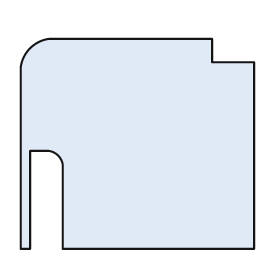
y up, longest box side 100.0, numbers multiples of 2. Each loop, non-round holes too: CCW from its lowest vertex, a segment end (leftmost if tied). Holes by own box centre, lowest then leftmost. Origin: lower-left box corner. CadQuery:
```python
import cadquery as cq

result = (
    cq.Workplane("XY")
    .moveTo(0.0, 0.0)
    .lineTo(4.0, 0.0)
    .lineTo(4.0, 42.0)
    .lineTo(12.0, 42.0)
    .threePointArc((16.0, 40.0), (18.0, 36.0))
    .lineTo(18.0, 0.0)
    .lineTo(100.0, 0.0)
    .lineTo(100.0, 80.0)
    .lineTo(82.0, 80.0)
    .lineTo(82.0, 90.0)
    .lineTo(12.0, 90.0)
    .threePointArc((4.0, 86.0), (0.0, 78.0))
    .close()
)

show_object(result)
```